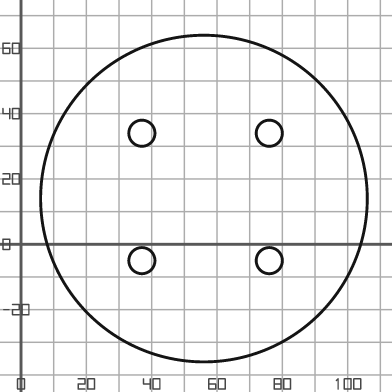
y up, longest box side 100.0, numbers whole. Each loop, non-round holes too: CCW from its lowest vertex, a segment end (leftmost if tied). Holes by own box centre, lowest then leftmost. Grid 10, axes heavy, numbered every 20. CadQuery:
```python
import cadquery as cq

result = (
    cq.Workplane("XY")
    .moveTo(56.0, 14.0)
    .circle(50.0)
    .moveTo(37.0, -5.0)
    .circle(4.0)
    .moveTo(76.0, -5.0)
    .circle(4.0)
    .moveTo(37.0, 34.0)
    .circle(4.0)
    .moveTo(76.0, 34.0)
    .circle(4.0)
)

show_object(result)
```